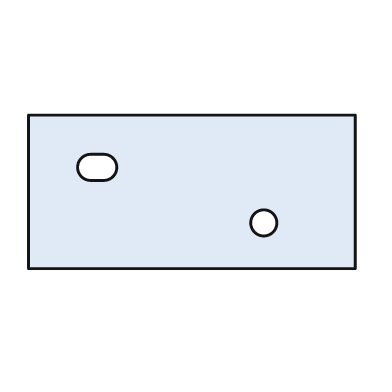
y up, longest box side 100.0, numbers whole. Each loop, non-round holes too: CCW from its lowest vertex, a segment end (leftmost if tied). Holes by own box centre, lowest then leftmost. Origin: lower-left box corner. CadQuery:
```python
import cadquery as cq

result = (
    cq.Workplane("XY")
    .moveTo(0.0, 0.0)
    .lineTo(100.0, 0.0)
    .lineTo(100.0, 47.0)
    .lineTo(0.0, 47.0)
    .close()
    .moveTo(72.0, 14.0)
    .circle(4.0)
    .moveTo(19.0, 27.0)
    .lineTo(23.0, 27.0)
    .threePointArc((27.0, 31.0), (23.0, 35.0))
    .lineTo(19.0, 35.0)
    .threePointArc((15.0, 31.0), (19.0, 27.0))
    .close()
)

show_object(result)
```